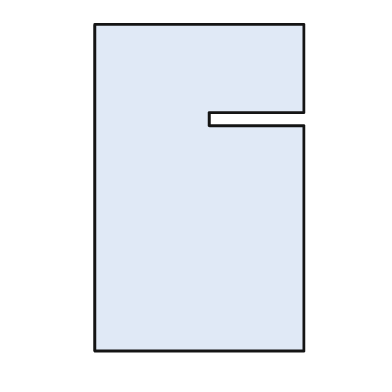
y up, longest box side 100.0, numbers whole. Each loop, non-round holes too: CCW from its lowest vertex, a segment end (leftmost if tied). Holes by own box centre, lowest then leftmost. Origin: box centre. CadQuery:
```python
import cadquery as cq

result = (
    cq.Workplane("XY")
    .moveTo(-32.0, -50.0)
    .lineTo(32.0, -50.0)
    .lineTo(32.0, 19.0)
    .lineTo(3.0, 19.0)
    .lineTo(3.0, 23.0)
    .lineTo(32.0, 23.0)
    .lineTo(32.0, 50.0)
    .lineTo(-32.0, 50.0)
    .close()
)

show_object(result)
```